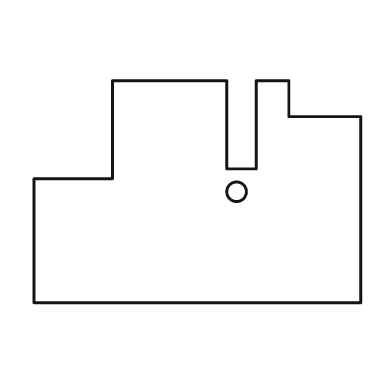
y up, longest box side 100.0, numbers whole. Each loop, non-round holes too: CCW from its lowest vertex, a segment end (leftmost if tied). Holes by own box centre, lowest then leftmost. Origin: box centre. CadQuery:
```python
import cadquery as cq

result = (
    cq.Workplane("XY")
    .moveTo(-50.0, -34.0)
    .lineTo(50.0, -34.0)
    .lineTo(50.0, 23.0)
    .lineTo(28.0, 23.0)
    .lineTo(28.0, 34.0)
    .lineTo(18.0, 34.0)
    .lineTo(18.0, 7.0)
    .lineTo(9.0, 7.0)
    .lineTo(9.0, 34.0)
    .lineTo(-26.0, 34.0)
    .lineTo(-26.0, 4.0)
    .lineTo(-50.0, 4.0)
    .close()
    .moveTo(12.0, 0.0)
    .circle(3.0)
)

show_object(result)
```